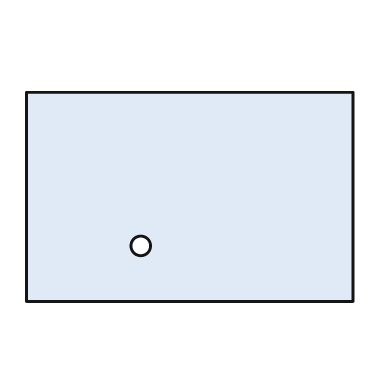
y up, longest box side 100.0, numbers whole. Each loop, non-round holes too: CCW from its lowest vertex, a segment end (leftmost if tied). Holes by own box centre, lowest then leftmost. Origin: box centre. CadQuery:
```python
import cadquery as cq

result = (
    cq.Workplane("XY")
    .moveTo(-50.0, -32.0)
    .lineTo(50.0, -32.0)
    .lineTo(50.0, 32.0)
    .lineTo(-50.0, 32.0)
    .close()
    .moveTo(-15.0, -15.0)
    .circle(3.0)
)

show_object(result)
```